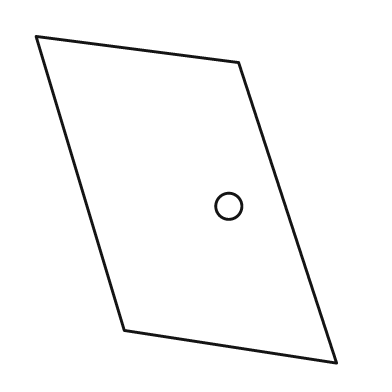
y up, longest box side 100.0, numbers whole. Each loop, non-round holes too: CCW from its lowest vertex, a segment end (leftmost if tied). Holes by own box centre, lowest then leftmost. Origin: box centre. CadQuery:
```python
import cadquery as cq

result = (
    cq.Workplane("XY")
    .moveTo(46.0, -50.0)
    .lineTo(16.0, 42.0)
    .lineTo(-46.0, 50.0)
    .lineTo(-19.0, -40.0)
    .close()
    .moveTo(13.0, -2.0)
    .circle(4.0)
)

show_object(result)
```